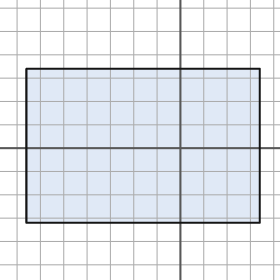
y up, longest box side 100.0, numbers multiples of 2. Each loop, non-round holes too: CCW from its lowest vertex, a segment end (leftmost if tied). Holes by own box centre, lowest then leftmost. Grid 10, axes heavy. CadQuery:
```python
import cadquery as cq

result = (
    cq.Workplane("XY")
    .moveTo(-66.0, -32.0)
    .lineTo(34.0, -32.0)
    .lineTo(34.0, 34.0)
    .lineTo(-66.0, 34.0)
    .close()
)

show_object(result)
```